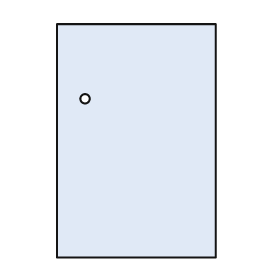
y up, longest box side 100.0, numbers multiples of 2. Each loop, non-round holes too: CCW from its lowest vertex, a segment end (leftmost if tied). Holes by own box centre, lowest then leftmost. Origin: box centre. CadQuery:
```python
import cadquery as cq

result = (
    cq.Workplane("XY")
    .moveTo(-34.0, -50.0)
    .lineTo(34.0, -50.0)
    .lineTo(34.0, 50.0)
    .lineTo(-34.0, 50.0)
    .close()
    .moveTo(-22.0, 18.0)
    .circle(2.0)
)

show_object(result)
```